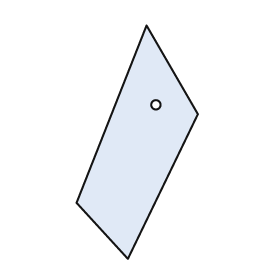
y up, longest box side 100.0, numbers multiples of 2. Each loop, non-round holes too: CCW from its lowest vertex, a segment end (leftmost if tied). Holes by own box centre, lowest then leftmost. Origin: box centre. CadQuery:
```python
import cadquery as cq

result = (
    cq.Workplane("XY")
    .moveTo(-4.0, -50.0)
    .lineTo(26.0, 12.0)
    .lineTo(4.0, 50.0)
    .lineTo(-26.0, -26.0)
    .close()
    .moveTo(8.0, 16.0)
    .circle(2.0)
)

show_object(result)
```